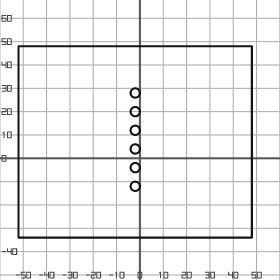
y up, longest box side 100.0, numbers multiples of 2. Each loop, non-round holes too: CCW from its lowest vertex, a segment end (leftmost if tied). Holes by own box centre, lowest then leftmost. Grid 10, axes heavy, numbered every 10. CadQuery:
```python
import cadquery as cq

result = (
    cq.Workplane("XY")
    .moveTo(-52.0, -34.0)
    .lineTo(48.0, -34.0)
    .lineTo(48.0, 48.0)
    .lineTo(-52.0, 48.0)
    .close()
    .moveTo(-2.0, -12.0)
    .circle(2.0)
    .moveTo(-2.0, -4.0)
    .circle(2.0)
    .moveTo(-2.0, 4.0)
    .circle(2.0)
    .moveTo(-2.0, 12.0)
    .circle(2.0)
    .moveTo(-2.0, 20.0)
    .circle(2.0)
    .moveTo(-2.0, 28.0)
    .circle(2.0)
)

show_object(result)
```